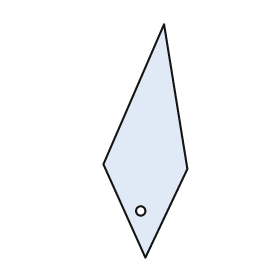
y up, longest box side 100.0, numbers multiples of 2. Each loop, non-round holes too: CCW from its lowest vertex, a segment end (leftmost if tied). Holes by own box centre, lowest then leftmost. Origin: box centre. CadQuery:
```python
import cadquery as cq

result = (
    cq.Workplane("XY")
    .moveTo(0.0, -50.0)
    .lineTo(18.0, -12.0)
    .lineTo(8.0, 50.0)
    .lineTo(-18.0, -10.0)
    .close()
    .moveTo(-2.0, -30.0)
    .circle(2.0)
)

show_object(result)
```